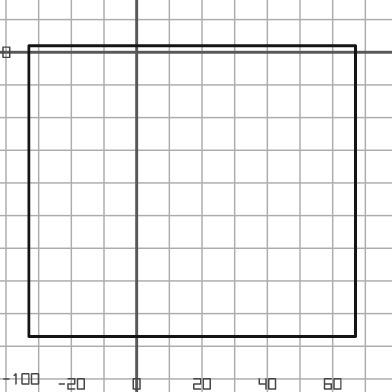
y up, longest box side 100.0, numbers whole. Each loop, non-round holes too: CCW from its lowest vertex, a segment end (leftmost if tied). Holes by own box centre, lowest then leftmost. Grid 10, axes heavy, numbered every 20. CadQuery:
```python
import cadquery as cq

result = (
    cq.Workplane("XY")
    .moveTo(-33.0, -87.0)
    .lineTo(67.0, -87.0)
    .lineTo(67.0, 2.0)
    .lineTo(-33.0, 2.0)
    .close()
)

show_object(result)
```